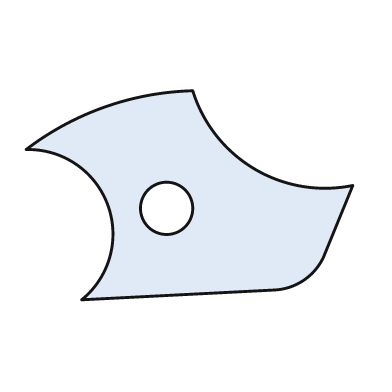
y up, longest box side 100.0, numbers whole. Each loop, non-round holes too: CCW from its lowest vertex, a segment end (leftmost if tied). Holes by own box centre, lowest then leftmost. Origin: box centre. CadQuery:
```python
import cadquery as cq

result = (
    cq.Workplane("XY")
    .moveTo(-33.0, -32.0)
    .lineTo(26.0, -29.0)
    .threePointArc((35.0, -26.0), (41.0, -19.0))
    .lineTo(50.0, 3.0)
    .threePointArc((20.0, 8.0), (1.0, 32.0))
    .threePointArc((-26.0, 27.0), (-50.0, 14.0))
    .threePointArc((-25.0, -3.0), (-33.0, -32.0))
    .close()
    .moveTo(-7.0, -4.0)
    .circle(8.0)
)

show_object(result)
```